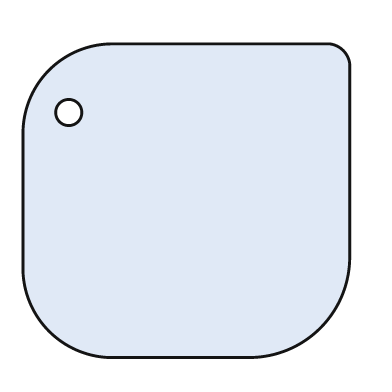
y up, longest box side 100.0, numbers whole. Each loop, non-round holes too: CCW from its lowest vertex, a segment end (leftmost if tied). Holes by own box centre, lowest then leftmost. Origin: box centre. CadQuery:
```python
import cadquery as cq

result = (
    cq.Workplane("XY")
    .moveTo(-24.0, -48.0)
    .lineTo(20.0, -48.0)
    .threePointArc((41.0, -39.0), (50.0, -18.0))
    .lineTo(50.0, 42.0)
    .threePointArc((48.0, 46.0), (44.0, 48.0))
    .lineTo(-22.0, 48.0)
    .threePointArc((-42.0, 40.0), (-50.0, 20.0))
    .lineTo(-50.0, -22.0)
    .threePointArc((-42.0, -40.0), (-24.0, -48.0))
    .close()
    .moveTo(-36.0, 27.0)
    .circle(4.0)
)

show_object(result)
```